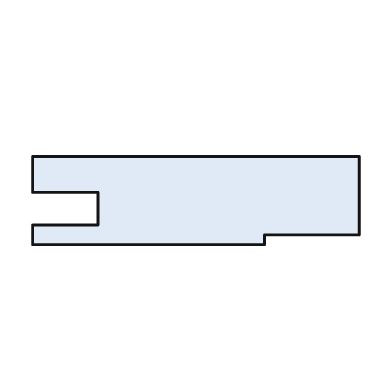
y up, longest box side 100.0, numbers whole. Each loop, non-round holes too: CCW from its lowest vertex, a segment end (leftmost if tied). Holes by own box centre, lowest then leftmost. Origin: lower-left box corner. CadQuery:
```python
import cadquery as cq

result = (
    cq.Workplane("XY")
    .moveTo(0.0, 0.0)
    .lineTo(71.0, 0.0)
    .lineTo(71.0, 3.0)
    .lineTo(100.0, 3.0)
    .lineTo(100.0, 27.0)
    .lineTo(0.0, 27.0)
    .lineTo(0.0, 16.0)
    .lineTo(20.0, 16.0)
    .lineTo(20.0, 6.0)
    .lineTo(0.0, 6.0)
    .close()
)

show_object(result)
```